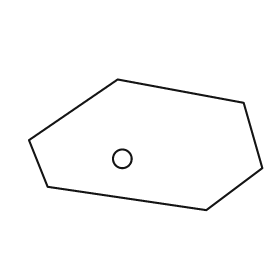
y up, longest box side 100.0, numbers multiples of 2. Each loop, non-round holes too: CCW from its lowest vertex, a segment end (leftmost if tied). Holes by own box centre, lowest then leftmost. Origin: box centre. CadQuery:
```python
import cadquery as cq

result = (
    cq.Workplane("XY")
    .moveTo(26.0, -28.0)
    .lineTo(50.0, -10.0)
    .lineTo(42.0, 18.0)
    .lineTo(-12.0, 28.0)
    .lineTo(-50.0, 2.0)
    .lineTo(-42.0, -18.0)
    .close()
    .moveTo(-10.0, -6.0)
    .circle(4.0)
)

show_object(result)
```